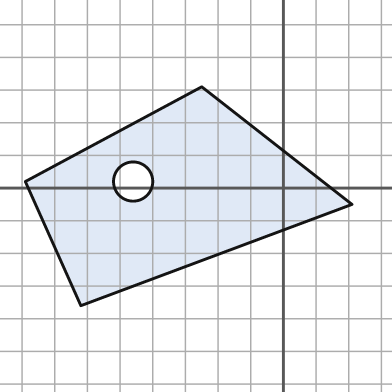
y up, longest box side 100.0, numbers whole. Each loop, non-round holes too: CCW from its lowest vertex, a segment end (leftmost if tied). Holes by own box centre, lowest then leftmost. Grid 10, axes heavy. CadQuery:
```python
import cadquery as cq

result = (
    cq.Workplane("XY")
    .moveTo(-62.0, -36.0)
    .lineTo(21.0, -5.0)
    .lineTo(-25.0, 31.0)
    .lineTo(-79.0, 2.0)
    .close()
    .moveTo(-46.0, 2.0)
    .circle(6.0)
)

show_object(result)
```